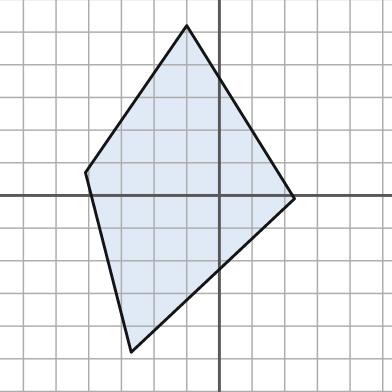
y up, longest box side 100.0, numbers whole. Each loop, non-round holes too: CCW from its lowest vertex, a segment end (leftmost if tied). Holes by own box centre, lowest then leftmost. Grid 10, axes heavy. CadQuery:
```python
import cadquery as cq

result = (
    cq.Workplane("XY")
    .moveTo(-27.0, -48.0)
    .lineTo(23.0, -1.0)
    .lineTo(-10.0, 52.0)
    .lineTo(-41.0, 7.0)
    .close()
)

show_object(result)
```